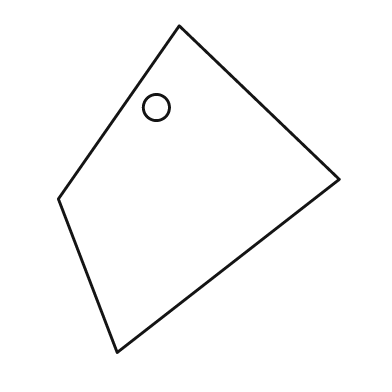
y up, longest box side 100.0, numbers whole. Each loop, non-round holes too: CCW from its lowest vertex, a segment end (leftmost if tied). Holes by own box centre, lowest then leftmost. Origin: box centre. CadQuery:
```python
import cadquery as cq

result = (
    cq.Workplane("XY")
    .moveTo(-25.0, -50.0)
    .lineTo(43.0, 3.0)
    .lineTo(-6.0, 50.0)
    .lineTo(-43.0, -3.0)
    .close()
    .moveTo(-13.0, 25.0)
    .circle(4.0)
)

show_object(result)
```